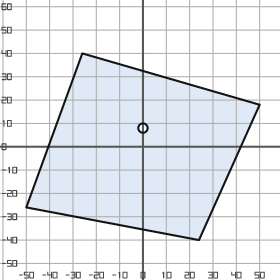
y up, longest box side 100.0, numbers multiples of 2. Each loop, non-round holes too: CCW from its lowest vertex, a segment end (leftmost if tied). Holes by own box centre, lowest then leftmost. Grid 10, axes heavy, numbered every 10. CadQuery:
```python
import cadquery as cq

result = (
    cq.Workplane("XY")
    .moveTo(24.0, -40.0)
    .lineTo(50.0, 18.0)
    .lineTo(-26.0, 40.0)
    .lineTo(-50.0, -26.0)
    .close()
    .moveTo(0.0, 8.0)
    .circle(2.0)
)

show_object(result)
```